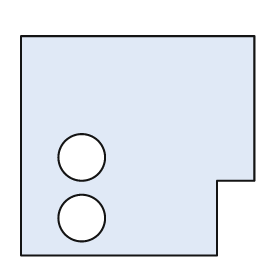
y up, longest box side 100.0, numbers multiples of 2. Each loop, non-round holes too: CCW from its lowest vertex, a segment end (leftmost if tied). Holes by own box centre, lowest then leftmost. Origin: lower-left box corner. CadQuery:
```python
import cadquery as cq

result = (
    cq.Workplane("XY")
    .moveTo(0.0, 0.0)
    .lineTo(84.0, 0.0)
    .lineTo(84.0, 32.0)
    .lineTo(100.0, 32.0)
    .lineTo(100.0, 94.0)
    .lineTo(0.0, 94.0)
    .close()
    .moveTo(26.0, 16.0)
    .circle(10.0)
    .moveTo(26.0, 42.0)
    .circle(10.0)
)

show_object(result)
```